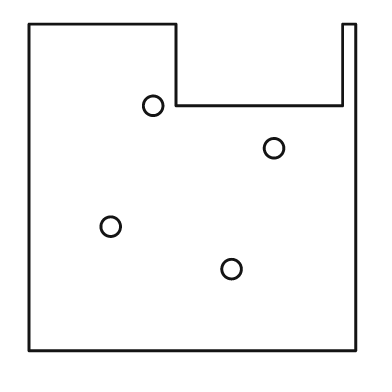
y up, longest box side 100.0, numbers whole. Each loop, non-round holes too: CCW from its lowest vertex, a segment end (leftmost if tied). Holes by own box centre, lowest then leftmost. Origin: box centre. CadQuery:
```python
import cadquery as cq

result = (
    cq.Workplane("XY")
    .moveTo(-50.0, -50.0)
    .lineTo(50.0, -50.0)
    .lineTo(50.0, 50.0)
    .lineTo(46.0, 50.0)
    .lineTo(46.0, 25.0)
    .lineTo(-5.0, 25.0)
    .lineTo(-5.0, 50.0)
    .lineTo(-50.0, 50.0)
    .close()
    .moveTo(12.0, -25.0)
    .circle(3.0)
    .moveTo(-25.0, -12.0)
    .circle(3.0)
    .moveTo(25.0, 12.0)
    .circle(3.0)
    .moveTo(-12.0, 25.0)
    .circle(3.0)
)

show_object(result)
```